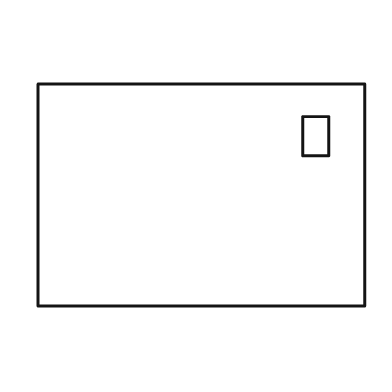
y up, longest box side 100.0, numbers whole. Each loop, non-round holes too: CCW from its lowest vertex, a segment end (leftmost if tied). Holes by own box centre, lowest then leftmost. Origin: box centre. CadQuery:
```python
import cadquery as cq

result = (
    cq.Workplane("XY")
    .moveTo(-50.0, -34.0)
    .lineTo(50.0, -34.0)
    .lineTo(50.0, 34.0)
    .lineTo(-50.0, 34.0)
    .close()
    .moveTo(31.0, 12.0)
    .lineTo(39.0, 12.0)
    .lineTo(39.0, 24.0)
    .lineTo(31.0, 24.0)
    .close()
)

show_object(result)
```